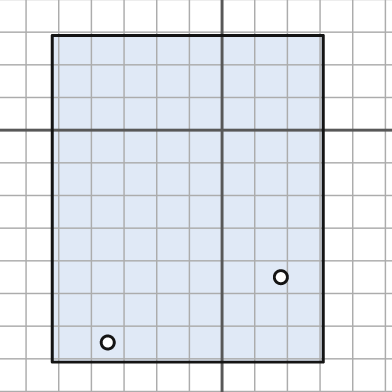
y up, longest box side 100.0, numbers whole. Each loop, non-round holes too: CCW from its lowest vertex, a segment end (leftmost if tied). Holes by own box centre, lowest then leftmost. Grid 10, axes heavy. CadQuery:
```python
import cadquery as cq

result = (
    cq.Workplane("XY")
    .moveTo(-52.0, -71.0)
    .lineTo(31.0, -71.0)
    .lineTo(31.0, 29.0)
    .lineTo(-52.0, 29.0)
    .close()
    .moveTo(-35.0, -65.0)
    .circle(2.0)
    .moveTo(18.0, -45.0)
    .circle(2.0)
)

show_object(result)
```